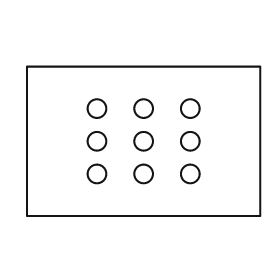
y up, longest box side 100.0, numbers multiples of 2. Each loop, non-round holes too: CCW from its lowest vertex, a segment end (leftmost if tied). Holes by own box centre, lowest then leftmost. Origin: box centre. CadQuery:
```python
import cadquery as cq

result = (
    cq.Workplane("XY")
    .moveTo(-50.0, -32.0)
    .lineTo(50.0, -32.0)
    .lineTo(50.0, 32.0)
    .lineTo(-50.0, 32.0)
    .close()
    .moveTo(-20.0, -14.0)
    .circle(4.0)
    .moveTo(0.0, -14.0)
    .circle(4.0)
    .moveTo(20.0, -14.0)
    .circle(4.0)
    .moveTo(-20.0, 0.0)
    .circle(4.0)
    .moveTo(0.0, 0.0)
    .circle(4.0)
    .moveTo(20.0, 0.0)
    .circle(4.0)
    .moveTo(-20.0, 14.0)
    .circle(4.0)
    .moveTo(0.0, 14.0)
    .circle(4.0)
    .moveTo(20.0, 14.0)
    .circle(4.0)
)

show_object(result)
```